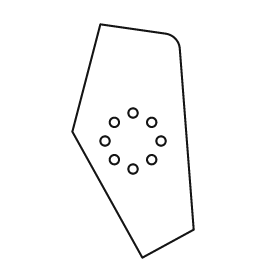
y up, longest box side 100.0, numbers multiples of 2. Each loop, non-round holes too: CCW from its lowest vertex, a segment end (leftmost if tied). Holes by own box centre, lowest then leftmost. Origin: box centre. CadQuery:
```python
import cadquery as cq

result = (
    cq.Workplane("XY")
    .moveTo(4.0, -50.0)
    .lineTo(26.0, -38.0)
    .lineTo(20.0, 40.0)
    .threePointArc((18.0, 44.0), (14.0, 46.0))
    .lineTo(-14.0, 50.0)
    .lineTo(-26.0, 4.0)
    .close()
    .moveTo(0.0, -12.0)
    .circle(2.0)
    .moveTo(-8.0, -8.0)
    .circle(2.0)
    .moveTo(8.0, -8.0)
    .circle(2.0)
    .moveTo(-12.0, 0.0)
    .circle(2.0)
    .moveTo(12.0, 0.0)
    .circle(2.0)
    .moveTo(-8.0, 8.0)
    .circle(2.0)
    .moveTo(8.0, 8.0)
    .circle(2.0)
    .moveTo(0.0, 12.0)
    .circle(2.0)
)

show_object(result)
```